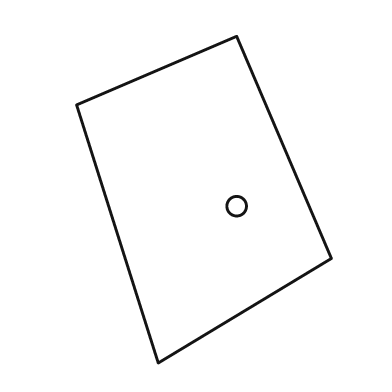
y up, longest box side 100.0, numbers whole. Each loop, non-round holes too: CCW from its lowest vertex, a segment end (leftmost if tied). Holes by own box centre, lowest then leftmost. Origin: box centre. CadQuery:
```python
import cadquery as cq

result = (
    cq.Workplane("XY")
    .moveTo(-14.0, -50.0)
    .lineTo(39.0, -18.0)
    .lineTo(10.0, 50.0)
    .lineTo(-39.0, 29.0)
    .close()
    .moveTo(10.0, -2.0)
    .circle(3.0)
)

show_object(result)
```